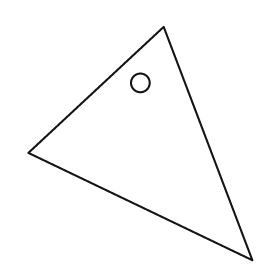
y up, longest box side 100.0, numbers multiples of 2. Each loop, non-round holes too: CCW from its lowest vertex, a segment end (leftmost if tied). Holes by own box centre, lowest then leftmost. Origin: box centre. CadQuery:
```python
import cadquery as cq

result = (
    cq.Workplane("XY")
    .moveTo(48.0, -50.0)
    .lineTo(10.0, 50.0)
    .lineTo(-48.0, -4.0)
    .close()
    .moveTo(0.0, 26.0)
    .circle(4.0)
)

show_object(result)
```